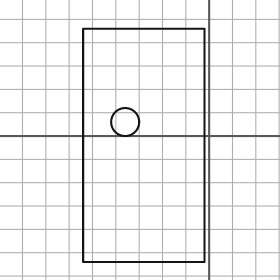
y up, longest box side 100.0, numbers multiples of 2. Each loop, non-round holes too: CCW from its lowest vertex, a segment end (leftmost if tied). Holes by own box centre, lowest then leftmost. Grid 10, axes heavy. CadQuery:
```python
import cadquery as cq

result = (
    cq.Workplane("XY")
    .moveTo(-54.0, -54.0)
    .lineTo(-2.0, -54.0)
    .lineTo(-2.0, 46.0)
    .lineTo(-54.0, 46.0)
    .close()
    .moveTo(-36.0, 6.0)
    .circle(6.0)
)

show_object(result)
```